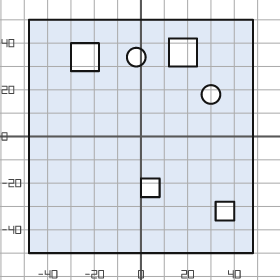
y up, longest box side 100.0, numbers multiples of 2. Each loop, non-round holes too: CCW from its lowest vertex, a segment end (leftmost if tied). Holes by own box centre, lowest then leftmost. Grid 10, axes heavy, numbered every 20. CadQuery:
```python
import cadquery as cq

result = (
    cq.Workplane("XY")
    .moveTo(-48.0, -50.0)
    .lineTo(48.0, -50.0)
    .lineTo(48.0, 50.0)
    .lineTo(-48.0, 50.0)
    .close()
    .moveTo(32.0, -36.0)
    .lineTo(40.0, -36.0)
    .lineTo(40.0, -28.0)
    .lineTo(32.0, -28.0)
    .close()
    .moveTo(0.0, -26.0)
    .lineTo(8.0, -26.0)
    .lineTo(8.0, -18.0)
    .lineTo(0.0, -18.0)
    .close()
    .moveTo(30.0, 18.0)
    .circle(4.0)
    .moveTo(-30.0, 28.0)
    .lineTo(-18.0, 28.0)
    .lineTo(-18.0, 40.0)
    .lineTo(-30.0, 40.0)
    .close()
    .moveTo(-2.0, 34.0)
    .circle(4.0)
    .moveTo(12.0, 30.0)
    .lineTo(24.0, 30.0)
    .lineTo(24.0, 42.0)
    .lineTo(12.0, 42.0)
    .close()
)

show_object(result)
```